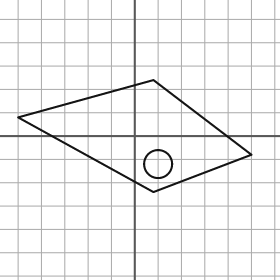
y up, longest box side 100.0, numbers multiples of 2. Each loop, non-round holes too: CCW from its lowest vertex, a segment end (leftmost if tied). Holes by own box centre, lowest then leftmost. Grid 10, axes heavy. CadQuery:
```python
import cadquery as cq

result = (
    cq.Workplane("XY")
    .moveTo(8.0, -24.0)
    .lineTo(50.0, -8.0)
    .lineTo(8.0, 24.0)
    .lineTo(-50.0, 8.0)
    .close()
    .moveTo(10.0, -12.0)
    .circle(6.0)
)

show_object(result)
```